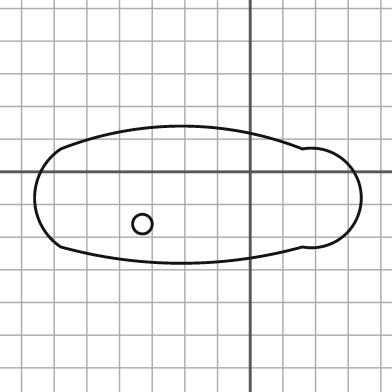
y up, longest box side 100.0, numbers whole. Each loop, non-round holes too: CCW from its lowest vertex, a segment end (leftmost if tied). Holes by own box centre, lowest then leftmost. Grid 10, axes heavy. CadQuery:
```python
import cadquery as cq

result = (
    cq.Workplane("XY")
    .moveTo(-58.0, -23.0)
    .threePointArc((-21.0, -28.0), (16.0, -23.0))
    .threePointArc((34.0, -8.0), (16.0, 7.0))
    .threePointArc((-21.0, 14.0), (-58.0, 7.0))
    .threePointArc((-66.0, -8.0), (-58.0, -23.0))
    .close()
    .moveTo(-33.0, -16.0)
    .circle(3.0)
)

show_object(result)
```